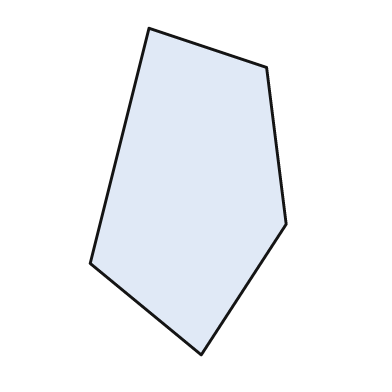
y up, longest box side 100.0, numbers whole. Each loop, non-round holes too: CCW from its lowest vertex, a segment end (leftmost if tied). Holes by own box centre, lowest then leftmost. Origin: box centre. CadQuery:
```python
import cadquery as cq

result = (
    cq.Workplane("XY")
    .moveTo(4.0, -50.0)
    .lineTo(30.0, -10.0)
    .lineTo(24.0, 38.0)
    .lineTo(-12.0, 50.0)
    .lineTo(-30.0, -22.0)
    .close()
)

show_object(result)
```